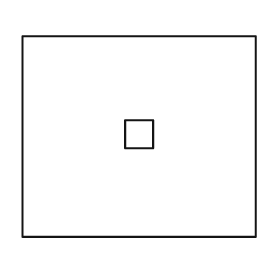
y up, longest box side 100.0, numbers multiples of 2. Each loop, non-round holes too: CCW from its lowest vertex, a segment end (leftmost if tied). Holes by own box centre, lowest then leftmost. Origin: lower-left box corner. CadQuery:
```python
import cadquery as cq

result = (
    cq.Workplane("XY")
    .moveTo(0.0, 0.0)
    .lineTo(100.0, 0.0)
    .lineTo(100.0, 86.0)
    .lineTo(0.0, 86.0)
    .close()
    .moveTo(44.0, 38.0)
    .lineTo(56.0, 38.0)
    .lineTo(56.0, 50.0)
    .lineTo(44.0, 50.0)
    .close()
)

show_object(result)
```